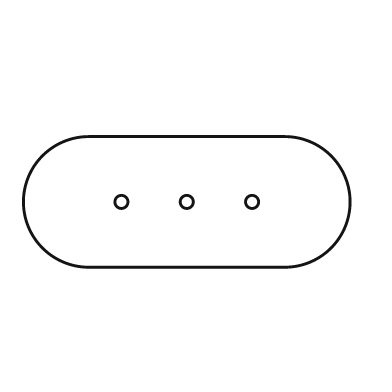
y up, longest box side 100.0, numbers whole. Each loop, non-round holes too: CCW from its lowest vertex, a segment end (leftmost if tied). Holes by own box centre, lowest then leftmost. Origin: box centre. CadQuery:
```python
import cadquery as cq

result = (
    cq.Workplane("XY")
    .moveTo(-30.0, -20.0)
    .lineTo(30.0, -20.0)
    .threePointArc((50.0, 0.0), (30.0, 20.0))
    .lineTo(-30.0, 20.0)
    .threePointArc((-50.0, 0.0), (-30.0, -20.0))
    .close()
    .moveTo(-20.0, 0.0)
    .circle(2.0)
    .moveTo(0.0, 0.0)
    .circle(2.0)
    .moveTo(20.0, 0.0)
    .circle(2.0)
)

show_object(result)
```